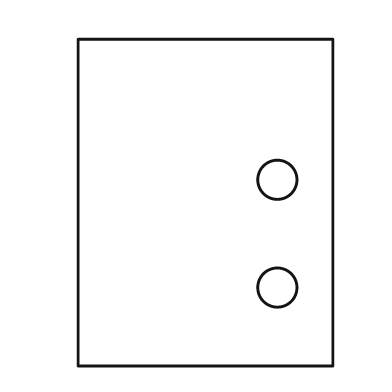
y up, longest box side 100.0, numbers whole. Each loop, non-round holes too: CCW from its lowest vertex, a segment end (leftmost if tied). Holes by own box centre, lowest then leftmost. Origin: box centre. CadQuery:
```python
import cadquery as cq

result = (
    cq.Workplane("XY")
    .moveTo(-39.0, -50.0)
    .lineTo(39.0, -50.0)
    .lineTo(39.0, 50.0)
    .lineTo(-39.0, 50.0)
    .close()
    .moveTo(22.0, -26.0)
    .circle(6.0)
    .moveTo(22.0, 7.0)
    .circle(6.0)
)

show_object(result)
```